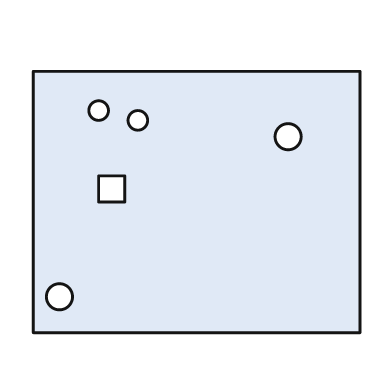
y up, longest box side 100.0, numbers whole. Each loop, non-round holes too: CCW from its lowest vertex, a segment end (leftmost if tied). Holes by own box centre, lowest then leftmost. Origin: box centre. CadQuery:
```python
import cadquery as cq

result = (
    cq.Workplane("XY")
    .moveTo(-50.0, -40.0)
    .lineTo(50.0, -40.0)
    .lineTo(50.0, 40.0)
    .lineTo(-50.0, 40.0)
    .close()
    .moveTo(-42.0, -29.0)
    .circle(4.0)
    .moveTo(-30.0, 0.0)
    .lineTo(-22.0, 0.0)
    .lineTo(-22.0, 8.0)
    .lineTo(-30.0, 8.0)
    .close()
    .moveTo(28.0, 20.0)
    .circle(4.0)
    .moveTo(-18.0, 25.0)
    .circle(3.0)
    .moveTo(-30.0, 28.0)
    .circle(3.0)
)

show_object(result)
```